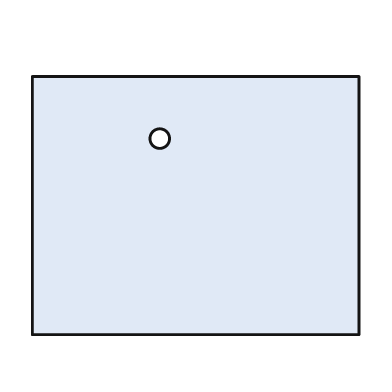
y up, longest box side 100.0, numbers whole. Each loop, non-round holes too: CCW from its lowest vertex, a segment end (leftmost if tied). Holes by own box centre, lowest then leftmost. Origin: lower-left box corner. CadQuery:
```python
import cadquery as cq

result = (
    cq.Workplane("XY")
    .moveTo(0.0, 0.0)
    .lineTo(100.0, 0.0)
    .lineTo(100.0, 79.0)
    .lineTo(0.0, 79.0)
    .close()
    .moveTo(39.0, 60.0)
    .circle(3.0)
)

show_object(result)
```